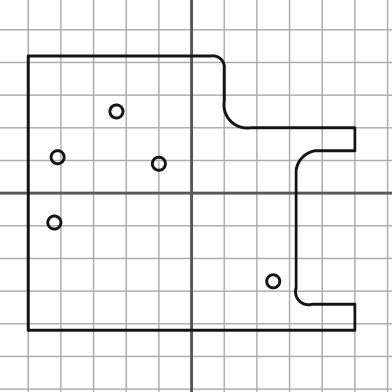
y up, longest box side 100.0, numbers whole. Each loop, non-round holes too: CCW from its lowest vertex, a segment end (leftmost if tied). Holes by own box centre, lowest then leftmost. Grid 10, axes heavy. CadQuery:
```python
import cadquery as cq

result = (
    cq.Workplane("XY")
    .moveTo(-50.0, -42.0)
    .lineTo(50.0, -42.0)
    .lineTo(50.0, -34.0)
    .lineTo(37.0, -34.0)
    .threePointArc((33.0, -33.0), (32.0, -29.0))
    .lineTo(32.0, 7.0)
    .threePointArc((34.0, 11.0), (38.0, 13.0))
    .lineTo(50.0, 13.0)
    .lineTo(50.0, 20.0)
    .lineTo(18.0, 20.0)
    .threePointArc((12.0, 22.0), (10.0, 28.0))
    .lineTo(10.0, 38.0)
    .threePointArc((9.0, 41.0), (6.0, 42.0))
    .lineTo(-50.0, 42.0)
    .close()
    .moveTo(25.0, -27.0)
    .circle(2.0)
    .moveTo(-42.0, -9.0)
    .circle(2.0)
    .moveTo(-10.0, 9.0)
    .circle(2.0)
    .moveTo(-41.0, 11.0)
    .circle(2.0)
    .moveTo(-23.0, 25.0)
    .circle(2.0)
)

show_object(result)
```